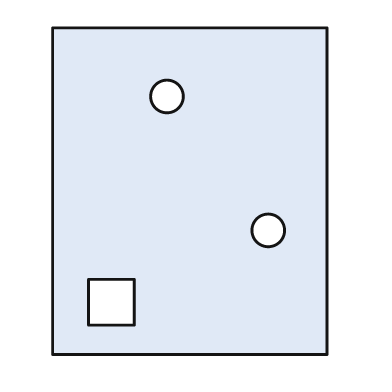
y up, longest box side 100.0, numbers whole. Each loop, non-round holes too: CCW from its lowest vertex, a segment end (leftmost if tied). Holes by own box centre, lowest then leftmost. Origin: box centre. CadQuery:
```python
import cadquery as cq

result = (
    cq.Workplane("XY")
    .moveTo(-42.0, -50.0)
    .lineTo(42.0, -50.0)
    .lineTo(42.0, 50.0)
    .lineTo(-42.0, 50.0)
    .close()
    .moveTo(-31.0, -41.0)
    .lineTo(-17.0, -41.0)
    .lineTo(-17.0, -27.0)
    .lineTo(-31.0, -27.0)
    .close()
    .moveTo(24.0, -12.0)
    .circle(5.0)
    .moveTo(-7.0, 29.0)
    .circle(5.0)
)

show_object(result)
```